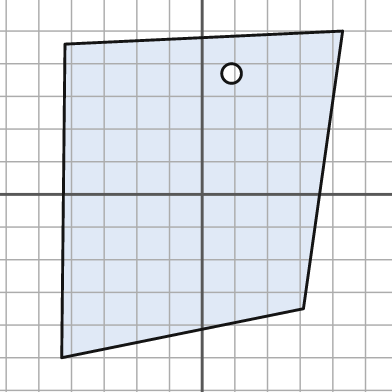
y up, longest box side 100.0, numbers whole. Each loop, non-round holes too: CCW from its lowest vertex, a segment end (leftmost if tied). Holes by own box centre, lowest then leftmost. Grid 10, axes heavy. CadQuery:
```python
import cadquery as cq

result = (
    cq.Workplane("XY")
    .moveTo(-43.0, -50.0)
    .lineTo(31.0, -35.0)
    .lineTo(43.0, 50.0)
    .lineTo(-42.0, 46.0)
    .close()
    .moveTo(9.0, 37.0)
    .circle(3.0)
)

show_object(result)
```